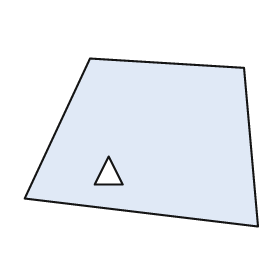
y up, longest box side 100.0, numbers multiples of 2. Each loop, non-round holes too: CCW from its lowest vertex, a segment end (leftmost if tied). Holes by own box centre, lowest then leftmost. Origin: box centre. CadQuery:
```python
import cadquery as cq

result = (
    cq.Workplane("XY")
    .moveTo(50.0, -36.0)
    .lineTo(44.0, 32.0)
    .lineTo(-22.0, 36.0)
    .lineTo(-50.0, -24.0)
    .close()
    .moveTo(-20.0, -18.0)
    .lineTo(-8.0, -18.0)
    .lineTo(-14.0, -6.0)
    .close()
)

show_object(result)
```